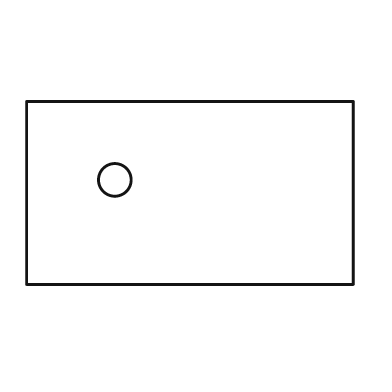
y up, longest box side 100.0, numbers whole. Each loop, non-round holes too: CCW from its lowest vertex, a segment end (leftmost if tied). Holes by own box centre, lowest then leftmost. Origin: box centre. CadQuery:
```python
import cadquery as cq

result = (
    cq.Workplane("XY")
    .moveTo(-50.0, -28.0)
    .lineTo(50.0, -28.0)
    .lineTo(50.0, 28.0)
    .lineTo(-50.0, 28.0)
    .close()
    .moveTo(-23.0, 4.0)
    .circle(5.0)
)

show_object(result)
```